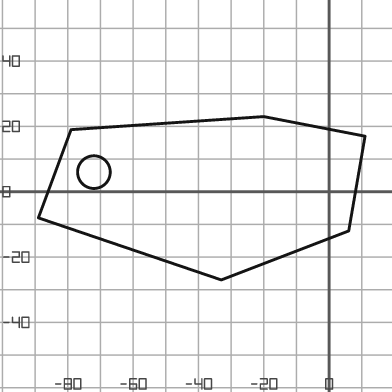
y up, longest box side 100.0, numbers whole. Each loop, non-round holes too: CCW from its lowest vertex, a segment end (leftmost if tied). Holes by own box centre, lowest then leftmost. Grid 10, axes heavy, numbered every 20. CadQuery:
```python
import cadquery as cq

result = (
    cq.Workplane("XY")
    .moveTo(-33.0, -27.0)
    .lineTo(6.0, -12.0)
    .lineTo(11.0, 17.0)
    .lineTo(-20.0, 23.0)
    .lineTo(-79.0, 19.0)
    .lineTo(-89.0, -8.0)
    .close()
    .moveTo(-72.0, 6.0)
    .circle(5.0)
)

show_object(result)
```